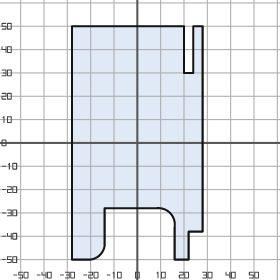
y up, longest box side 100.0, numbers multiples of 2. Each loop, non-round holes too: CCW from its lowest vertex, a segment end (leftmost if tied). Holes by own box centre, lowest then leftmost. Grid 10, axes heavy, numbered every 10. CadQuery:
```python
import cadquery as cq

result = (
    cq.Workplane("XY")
    .moveTo(-28.0, -50.0)
    .lineTo(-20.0, -50.0)
    .threePointArc((-16.0, -48.0), (-14.0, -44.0))
    .lineTo(-14.0, -28.0)
    .lineTo(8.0, -28.0)
    .threePointArc((14.0, -30.0), (16.0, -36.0))
    .lineTo(16.0, -50.0)
    .lineTo(22.0, -50.0)
    .lineTo(22.0, -38.0)
    .lineTo(28.0, -38.0)
    .lineTo(28.0, 50.0)
    .lineTo(24.0, 50.0)
    .lineTo(24.0, 30.0)
    .lineTo(20.0, 30.0)
    .lineTo(20.0, 50.0)
    .lineTo(-28.0, 50.0)
    .close()
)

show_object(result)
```